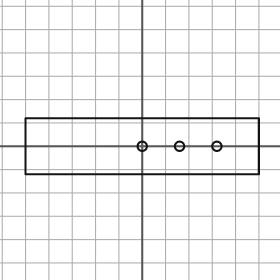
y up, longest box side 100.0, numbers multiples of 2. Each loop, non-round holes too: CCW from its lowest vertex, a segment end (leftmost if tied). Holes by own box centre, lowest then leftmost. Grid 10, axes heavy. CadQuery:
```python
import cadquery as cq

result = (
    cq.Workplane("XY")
    .moveTo(-50.0, -12.0)
    .lineTo(50.0, -12.0)
    .lineTo(50.0, 12.0)
    .lineTo(-50.0, 12.0)
    .close()
    .moveTo(0.0, 0.0)
    .circle(2.0)
    .moveTo(16.0, 0.0)
    .circle(2.0)
    .moveTo(32.0, 0.0)
    .circle(2.0)
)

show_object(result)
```